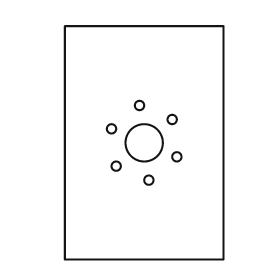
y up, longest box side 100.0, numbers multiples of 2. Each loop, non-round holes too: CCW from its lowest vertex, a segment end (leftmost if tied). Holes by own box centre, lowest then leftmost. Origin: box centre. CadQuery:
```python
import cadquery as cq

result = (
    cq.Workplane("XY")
    .moveTo(-34.0, -50.0)
    .lineTo(34.0, -50.0)
    .lineTo(34.0, 50.0)
    .lineTo(-34.0, 50.0)
    .close()
    .moveTo(2.0, -16.0)
    .circle(2.0)
    .moveTo(-12.0, -10.0)
    .circle(2.0)
    .moveTo(14.0, -6.0)
    .circle(2.0)
    .moveTo(0.0, 0.0)
    .circle(8.0)
    .moveTo(-14.0, 6.0)
    .circle(2.0)
    .moveTo(12.0, 10.0)
    .circle(2.0)
    .moveTo(-2.0, 16.0)
    .circle(2.0)
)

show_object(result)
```